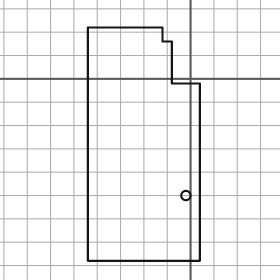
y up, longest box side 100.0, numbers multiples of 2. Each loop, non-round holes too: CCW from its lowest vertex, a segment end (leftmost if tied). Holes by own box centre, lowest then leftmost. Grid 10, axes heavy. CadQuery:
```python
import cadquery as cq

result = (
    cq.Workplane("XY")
    .moveTo(-44.0, -78.0)
    .lineTo(4.0, -78.0)
    .lineTo(4.0, -2.0)
    .lineTo(-8.0, -2.0)
    .lineTo(-8.0, 16.0)
    .lineTo(-12.0, 16.0)
    .lineTo(-12.0, 22.0)
    .lineTo(-44.0, 22.0)
    .close()
    .moveTo(-2.0, -50.0)
    .circle(2.0)
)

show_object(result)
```